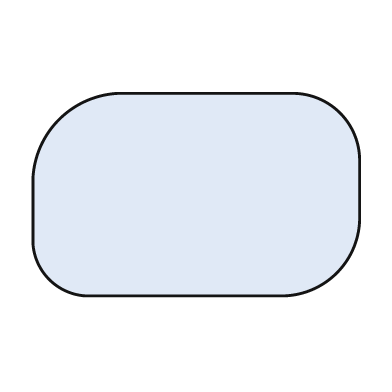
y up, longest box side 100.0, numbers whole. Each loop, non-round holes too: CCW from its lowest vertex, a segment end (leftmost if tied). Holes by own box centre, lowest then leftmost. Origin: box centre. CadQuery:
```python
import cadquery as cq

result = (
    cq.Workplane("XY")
    .moveTo(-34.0, -31.0)
    .lineTo(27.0, -31.0)
    .threePointArc((43.0, -24.0), (50.0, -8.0))
    .lineTo(50.0, 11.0)
    .threePointArc((44.0, 25.0), (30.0, 31.0))
    .lineTo(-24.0, 31.0)
    .threePointArc((-42.0, 23.0), (-50.0, 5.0))
    .lineTo(-50.0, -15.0)
    .threePointArc((-45.0, -26.0), (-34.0, -31.0))
    .close()
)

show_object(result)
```